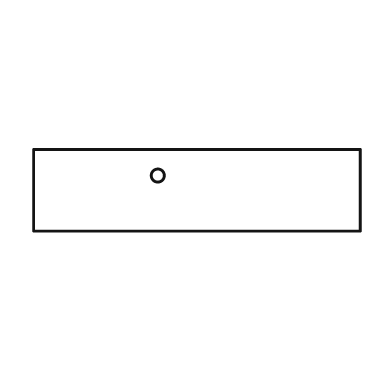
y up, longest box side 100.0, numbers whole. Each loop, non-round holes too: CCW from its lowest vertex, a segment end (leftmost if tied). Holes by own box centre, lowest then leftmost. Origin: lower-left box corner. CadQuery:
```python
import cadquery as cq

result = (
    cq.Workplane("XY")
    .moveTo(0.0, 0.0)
    .lineTo(100.0, 0.0)
    .lineTo(100.0, 25.0)
    .lineTo(0.0, 25.0)
    .close()
    .moveTo(38.0, 17.0)
    .circle(2.0)
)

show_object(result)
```